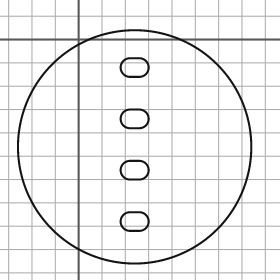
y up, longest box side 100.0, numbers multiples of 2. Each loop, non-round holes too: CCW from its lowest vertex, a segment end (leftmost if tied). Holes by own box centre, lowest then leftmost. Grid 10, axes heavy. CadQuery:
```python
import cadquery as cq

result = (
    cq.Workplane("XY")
    .moveTo(24.0, -46.0)
    .circle(50.0)
    .moveTo(22.0, -82.0)
    .lineTo(26.0, -82.0)
    .threePointArc((30.0, -78.0), (26.0, -74.0))
    .lineTo(22.0, -74.0)
    .threePointArc((18.0, -78.0), (22.0, -82.0))
    .close()
    .moveTo(22.0, -60.0)
    .lineTo(26.0, -60.0)
    .threePointArc((30.0, -56.0), (26.0, -52.0))
    .lineTo(22.0, -52.0)
    .threePointArc((18.0, -56.0), (22.0, -60.0))
    .close()
    .moveTo(22.0, -38.0)
    .lineTo(26.0, -38.0)
    .threePointArc((30.0, -34.0), (26.0, -30.0))
    .lineTo(22.0, -30.0)
    .threePointArc((18.0, -34.0), (22.0, -38.0))
    .close()
    .moveTo(22.0, -16.0)
    .lineTo(26.0, -16.0)
    .threePointArc((30.0, -12.0), (26.0, -8.0))
    .lineTo(22.0, -8.0)
    .threePointArc((18.0, -12.0), (22.0, -16.0))
    .close()
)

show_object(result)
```